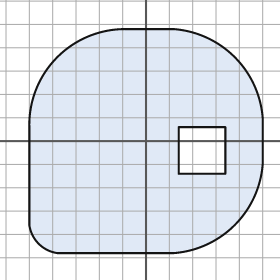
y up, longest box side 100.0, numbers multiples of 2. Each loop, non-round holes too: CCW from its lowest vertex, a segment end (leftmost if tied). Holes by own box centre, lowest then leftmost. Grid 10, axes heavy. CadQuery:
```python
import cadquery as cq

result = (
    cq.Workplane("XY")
    .moveTo(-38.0, -48.0)
    .lineTo(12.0, -48.0)
    .threePointArc((38.0, -36.0), (50.0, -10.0))
    .lineTo(50.0, 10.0)
    .threePointArc((38.0, 36.0), (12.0, 48.0))
    .lineTo(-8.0, 48.0)
    .threePointArc((-38.0, 36.0), (-50.0, 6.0))
    .lineTo(-50.0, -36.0)
    .threePointArc((-46.0, -44.0), (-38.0, -48.0))
    .close()
    .moveTo(14.0, -14.0)
    .lineTo(34.0, -14.0)
    .lineTo(34.0, 6.0)
    .lineTo(14.0, 6.0)
    .close()
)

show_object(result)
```